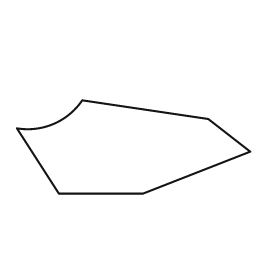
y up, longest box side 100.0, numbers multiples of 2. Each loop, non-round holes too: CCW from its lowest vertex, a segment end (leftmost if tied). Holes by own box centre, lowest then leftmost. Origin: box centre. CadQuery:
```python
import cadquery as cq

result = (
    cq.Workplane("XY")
    .moveTo(-32.0, -20.0)
    .lineTo(4.0, -20.0)
    .lineTo(50.0, -2.0)
    .lineTo(32.0, 12.0)
    .lineTo(-22.0, 20.0)
    .threePointArc((-34.0, 10.0), (-50.0, 8.0))
    .close()
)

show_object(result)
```